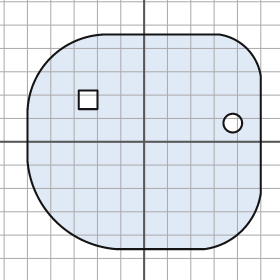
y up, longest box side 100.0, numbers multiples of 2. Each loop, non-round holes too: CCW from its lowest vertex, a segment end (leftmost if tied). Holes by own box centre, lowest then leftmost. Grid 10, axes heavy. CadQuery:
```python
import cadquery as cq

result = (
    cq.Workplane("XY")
    .moveTo(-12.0, -46.0)
    .lineTo(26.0, -46.0)
    .threePointArc((42.0, -38.0), (50.0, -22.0))
    .lineTo(50.0, 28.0)
    .threePointArc((44.0, 40.0), (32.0, 46.0))
    .lineTo(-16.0, 46.0)
    .threePointArc((-40.0, 36.0), (-50.0, 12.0))
    .lineTo(-50.0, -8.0)
    .threePointArc((-38.0, -34.0), (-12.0, -46.0))
    .close()
    .moveTo(38.0, 8.0)
    .circle(4.0)
    .moveTo(-28.0, 14.0)
    .lineTo(-20.0, 14.0)
    .lineTo(-20.0, 22.0)
    .lineTo(-28.0, 22.0)
    .close()
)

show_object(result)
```